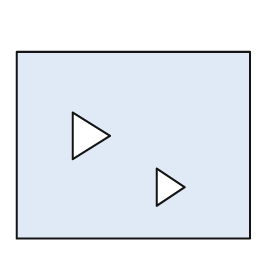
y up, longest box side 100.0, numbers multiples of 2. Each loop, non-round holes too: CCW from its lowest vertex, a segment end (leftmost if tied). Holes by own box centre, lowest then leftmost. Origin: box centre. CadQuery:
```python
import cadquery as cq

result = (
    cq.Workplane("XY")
    .moveTo(-50.0, -40.0)
    .lineTo(50.0, -40.0)
    .lineTo(50.0, 40.0)
    .lineTo(-50.0, 40.0)
    .close()
    .moveTo(10.0, -26.0)
    .lineTo(22.0, -18.0)
    .lineTo(10.0, -10.0)
    .close()
    .moveTo(-26.0, -6.0)
    .lineTo(-10.0, 4.0)
    .lineTo(-26.0, 14.0)
    .close()
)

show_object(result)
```